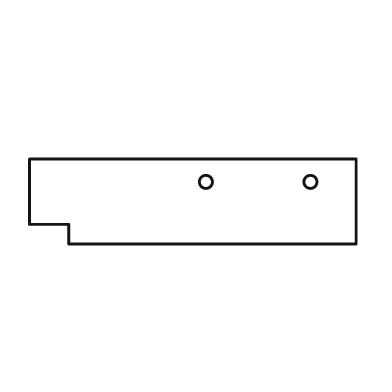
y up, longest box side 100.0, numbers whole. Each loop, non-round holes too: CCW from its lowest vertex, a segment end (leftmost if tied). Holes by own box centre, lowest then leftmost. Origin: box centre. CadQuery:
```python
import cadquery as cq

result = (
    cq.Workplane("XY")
    .moveTo(-38.0, -13.0)
    .lineTo(50.0, -13.0)
    .lineTo(50.0, 13.0)
    .lineTo(-50.0, 13.0)
    .lineTo(-50.0, -7.0)
    .lineTo(-38.0, -7.0)
    .close()
    .moveTo(4.0, 6.0)
    .circle(2.0)
    .moveTo(36.0, 6.0)
    .circle(2.0)
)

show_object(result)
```